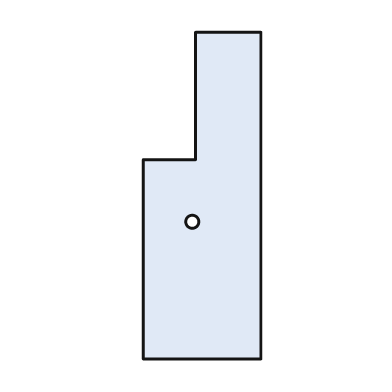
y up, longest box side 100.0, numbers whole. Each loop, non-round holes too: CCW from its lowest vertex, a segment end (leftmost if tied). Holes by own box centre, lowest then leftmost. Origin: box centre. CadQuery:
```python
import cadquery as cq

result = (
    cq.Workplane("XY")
    .moveTo(-18.0, -50.0)
    .lineTo(18.0, -50.0)
    .lineTo(18.0, 50.0)
    .lineTo(-2.0, 50.0)
    .lineTo(-2.0, 11.0)
    .lineTo(-18.0, 11.0)
    .close()
    .moveTo(-3.0, -8.0)
    .circle(2.0)
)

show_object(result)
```